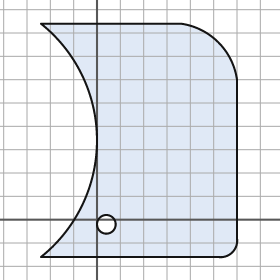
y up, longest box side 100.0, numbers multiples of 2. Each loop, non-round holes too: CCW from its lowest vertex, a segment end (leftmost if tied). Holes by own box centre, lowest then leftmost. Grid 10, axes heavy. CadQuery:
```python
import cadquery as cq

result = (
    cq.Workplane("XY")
    .moveTo(-24.0, -16.0)
    .lineTo(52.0, -16.0)
    .threePointArc((58.0, -14.0), (60.0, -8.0))
    .lineTo(60.0, 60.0)
    .threePointArc((52.0, 76.0), (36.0, 84.0))
    .lineTo(-24.0, 84.0)
    .threePointArc((0.0, 34.0), (-24.0, -16.0))
    .close()
    .moveTo(4.0, -2.0)
    .circle(4.0)
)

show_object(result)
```